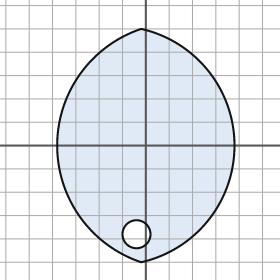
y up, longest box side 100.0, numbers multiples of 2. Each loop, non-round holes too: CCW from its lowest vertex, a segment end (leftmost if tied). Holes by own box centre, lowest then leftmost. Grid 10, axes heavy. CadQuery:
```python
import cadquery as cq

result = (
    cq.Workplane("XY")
    .moveTo(-2.0, -50.0)
    .threePointArc((38.0, 0.0), (-2.0, 50.0))
    .threePointArc((-38.0, 0.0), (-2.0, -50.0))
    .close()
    .moveTo(-4.0, -38.0)
    .circle(6.0)
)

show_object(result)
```